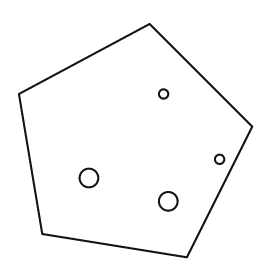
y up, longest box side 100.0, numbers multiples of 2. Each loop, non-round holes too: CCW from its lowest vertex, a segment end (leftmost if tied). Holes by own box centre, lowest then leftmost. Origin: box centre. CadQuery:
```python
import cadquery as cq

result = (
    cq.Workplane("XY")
    .moveTo(22.0, -50.0)
    .lineTo(50.0, 6.0)
    .lineTo(6.0, 50.0)
    .lineTo(-50.0, 20.0)
    .lineTo(-40.0, -40.0)
    .close()
    .moveTo(14.0, -26.0)
    .circle(4.0)
    .moveTo(-20.0, -16.0)
    .circle(4.0)
    .moveTo(36.0, -8.0)
    .circle(2.0)
    .moveTo(12.0, 20.0)
    .circle(2.0)
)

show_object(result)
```